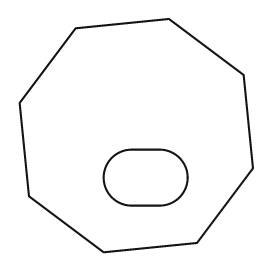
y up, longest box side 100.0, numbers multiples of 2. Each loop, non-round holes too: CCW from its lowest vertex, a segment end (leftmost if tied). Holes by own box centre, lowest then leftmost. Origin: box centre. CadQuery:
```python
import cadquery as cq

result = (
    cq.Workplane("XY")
    .moveTo(-14.0, -50.0)
    .lineTo(26.0, -46.0)
    .lineTo(50.0, -14.0)
    .lineTo(46.0, 26.0)
    .lineTo(14.0, 50.0)
    .lineTo(-26.0, 46.0)
    .lineTo(-50.0, 14.0)
    .lineTo(-46.0, -26.0)
    .close()
    .moveTo(-2.0, -30.0)
    .lineTo(10.0, -30.0)
    .threePointArc((22.0, -18.0), (10.0, -6.0))
    .lineTo(-2.0, -6.0)
    .threePointArc((-14.0, -18.0), (-2.0, -30.0))
    .close()
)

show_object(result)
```